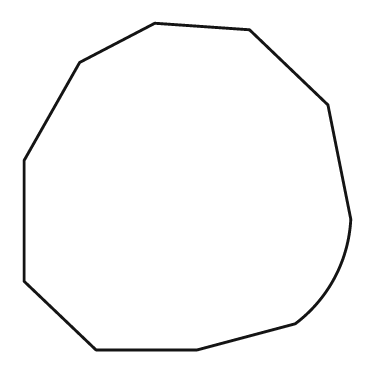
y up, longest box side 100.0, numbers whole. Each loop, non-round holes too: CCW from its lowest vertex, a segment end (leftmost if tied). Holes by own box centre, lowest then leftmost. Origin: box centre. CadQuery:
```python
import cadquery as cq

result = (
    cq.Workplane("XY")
    .moveTo(-28.0, -50.0)
    .lineTo(3.0, -50.0)
    .lineTo(33.0, -42.0)
    .threePointArc((45.0, -28.0), (50.0, -10.0))
    .lineTo(43.0, 25.0)
    .lineTo(19.0, 48.0)
    .lineTo(-10.0, 50.0)
    .lineTo(-33.0, 38.0)
    .lineTo(-50.0, 8.0)
    .lineTo(-50.0, -29.0)
    .close()
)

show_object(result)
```